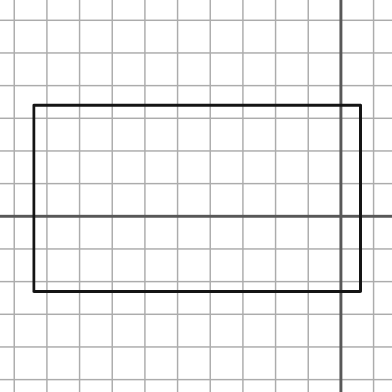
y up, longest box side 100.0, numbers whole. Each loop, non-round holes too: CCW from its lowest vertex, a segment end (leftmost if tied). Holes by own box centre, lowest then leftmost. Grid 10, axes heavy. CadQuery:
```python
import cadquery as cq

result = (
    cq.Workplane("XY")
    .moveTo(-94.0, -23.0)
    .lineTo(6.0, -23.0)
    .lineTo(6.0, 34.0)
    .lineTo(-94.0, 34.0)
    .close()
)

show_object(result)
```